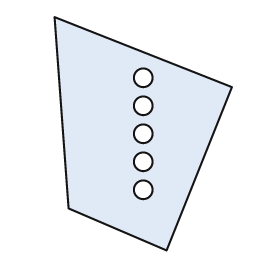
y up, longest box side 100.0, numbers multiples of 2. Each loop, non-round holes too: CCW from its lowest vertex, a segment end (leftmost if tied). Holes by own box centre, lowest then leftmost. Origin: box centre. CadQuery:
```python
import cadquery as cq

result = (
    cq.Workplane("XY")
    .moveTo(10.0, -50.0)
    .lineTo(38.0, 20.0)
    .lineTo(-38.0, 50.0)
    .lineTo(-32.0, -32.0)
    .close()
    .moveTo(0.0, -24.0)
    .circle(4.0)
    .moveTo(0.0, -12.0)
    .circle(4.0)
    .moveTo(0.0, 0.0)
    .circle(4.0)
    .moveTo(0.0, 12.0)
    .circle(4.0)
    .moveTo(0.0, 24.0)
    .circle(4.0)
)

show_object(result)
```